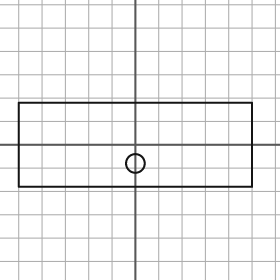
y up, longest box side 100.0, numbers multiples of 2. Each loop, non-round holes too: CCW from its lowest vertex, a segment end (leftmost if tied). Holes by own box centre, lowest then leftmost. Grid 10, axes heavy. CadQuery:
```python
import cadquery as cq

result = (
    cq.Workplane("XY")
    .moveTo(-50.0, -18.0)
    .lineTo(50.0, -18.0)
    .lineTo(50.0, 18.0)
    .lineTo(-50.0, 18.0)
    .close()
    .moveTo(0.0, -8.0)
    .circle(4.0)
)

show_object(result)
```